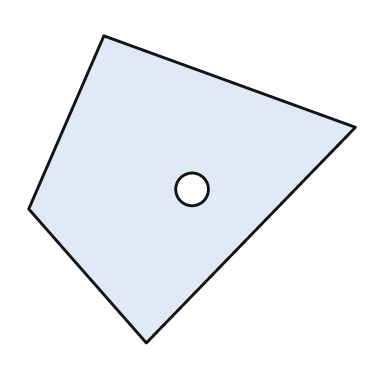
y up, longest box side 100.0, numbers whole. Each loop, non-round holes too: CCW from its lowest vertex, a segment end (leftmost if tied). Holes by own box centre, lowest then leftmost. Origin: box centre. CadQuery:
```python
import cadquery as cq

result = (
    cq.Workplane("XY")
    .moveTo(-14.0, -47.0)
    .lineTo(50.0, 19.0)
    .lineTo(-27.0, 47.0)
    .lineTo(-50.0, -6.0)
    .close()
    .moveTo(0.0, 0.0)
    .circle(5.0)
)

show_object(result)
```